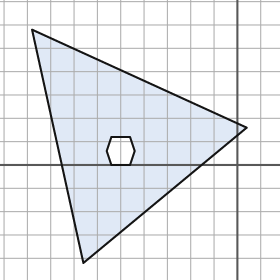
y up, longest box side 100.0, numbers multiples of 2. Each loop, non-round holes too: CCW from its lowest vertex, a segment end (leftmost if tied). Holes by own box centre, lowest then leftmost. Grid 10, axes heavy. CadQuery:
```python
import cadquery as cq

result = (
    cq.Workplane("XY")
    .moveTo(-66.0, -42.0)
    .lineTo(4.0, 16.0)
    .lineTo(-88.0, 58.0)
    .close()
    .moveTo(-54.0, 0.0)
    .lineTo(-46.0, 0.0)
    .lineTo(-44.0, 6.0)
    .lineTo(-46.0, 12.0)
    .lineTo(-54.0, 12.0)
    .lineTo(-56.0, 6.0)
    .close()
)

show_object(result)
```